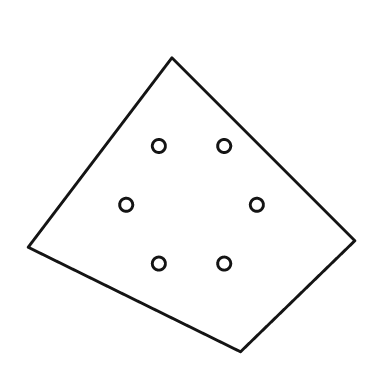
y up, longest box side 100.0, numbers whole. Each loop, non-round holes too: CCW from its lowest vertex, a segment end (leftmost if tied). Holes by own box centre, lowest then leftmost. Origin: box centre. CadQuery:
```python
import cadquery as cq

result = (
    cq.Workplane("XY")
    .moveTo(15.0, -45.0)
    .lineTo(50.0, -11.0)
    .lineTo(-6.0, 45.0)
    .lineTo(-50.0, -13.0)
    .close()
    .moveTo(-10.0, -18.0)
    .circle(2.0)
    .moveTo(10.0, -18.0)
    .circle(2.0)
    .moveTo(-20.0, 0.0)
    .circle(2.0)
    .moveTo(20.0, 0.0)
    .circle(2.0)
    .moveTo(-10.0, 18.0)
    .circle(2.0)
    .moveTo(10.0, 18.0)
    .circle(2.0)
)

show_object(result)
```